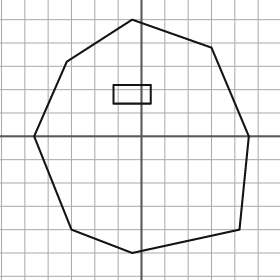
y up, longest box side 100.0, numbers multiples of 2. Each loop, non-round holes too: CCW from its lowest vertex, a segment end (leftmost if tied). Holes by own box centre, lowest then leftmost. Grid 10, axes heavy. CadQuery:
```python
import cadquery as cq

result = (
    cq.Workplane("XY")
    .moveTo(-4.0, -50.0)
    .lineTo(42.0, -40.0)
    .lineTo(46.0, 0.0)
    .lineTo(30.0, 38.0)
    .lineTo(-4.0, 50.0)
    .lineTo(-32.0, 32.0)
    .lineTo(-46.0, 0.0)
    .lineTo(-30.0, -40.0)
    .close()
    .moveTo(-12.0, 14.0)
    .lineTo(4.0, 14.0)
    .lineTo(4.0, 22.0)
    .lineTo(-12.0, 22.0)
    .close()
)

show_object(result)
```